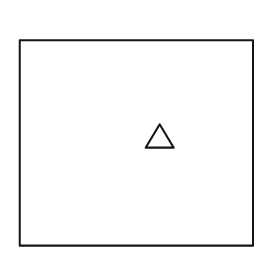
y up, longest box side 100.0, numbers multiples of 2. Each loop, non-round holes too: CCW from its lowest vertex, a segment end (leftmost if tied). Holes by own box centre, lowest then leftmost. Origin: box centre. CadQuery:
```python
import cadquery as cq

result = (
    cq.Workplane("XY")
    .moveTo(-50.0, -44.0)
    .lineTo(50.0, -44.0)
    .lineTo(50.0, 44.0)
    .lineTo(-50.0, 44.0)
    .close()
    .moveTo(4.0, -2.0)
    .lineTo(16.0, -2.0)
    .lineTo(10.0, 8.0)
    .close()
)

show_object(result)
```